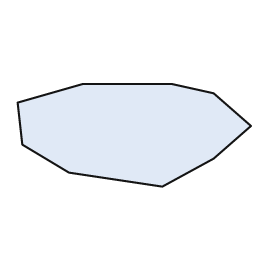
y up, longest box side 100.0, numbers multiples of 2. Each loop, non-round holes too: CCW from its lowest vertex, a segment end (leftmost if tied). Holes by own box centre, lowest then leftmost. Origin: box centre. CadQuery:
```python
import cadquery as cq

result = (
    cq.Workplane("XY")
    .moveTo(12.0, -22.0)
    .lineTo(34.0, -10.0)
    .lineTo(50.0, 4.0)
    .lineTo(34.0, 18.0)
    .lineTo(16.0, 22.0)
    .lineTo(-22.0, 22.0)
    .lineTo(-50.0, 14.0)
    .lineTo(-48.0, -4.0)
    .lineTo(-28.0, -16.0)
    .close()
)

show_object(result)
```